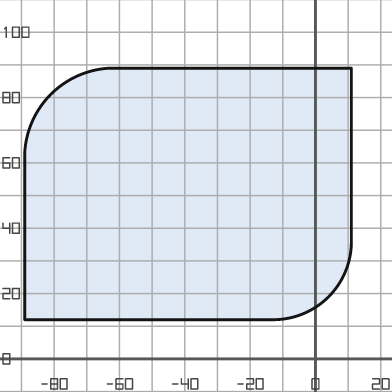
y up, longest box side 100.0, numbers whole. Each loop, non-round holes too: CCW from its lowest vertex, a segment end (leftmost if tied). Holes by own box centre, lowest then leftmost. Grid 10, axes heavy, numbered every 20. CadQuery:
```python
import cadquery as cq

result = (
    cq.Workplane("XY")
    .moveTo(-89.0, 12.0)
    .lineTo(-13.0, 12.0)
    .threePointArc((4.0, 19.0), (11.0, 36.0))
    .lineTo(11.0, 89.0)
    .lineTo(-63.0, 89.0)
    .threePointArc((-81.0, 81.0), (-89.0, 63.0))
    .close()
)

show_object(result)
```